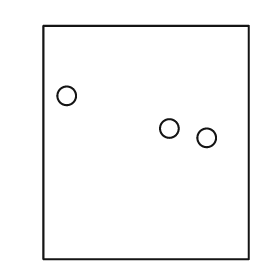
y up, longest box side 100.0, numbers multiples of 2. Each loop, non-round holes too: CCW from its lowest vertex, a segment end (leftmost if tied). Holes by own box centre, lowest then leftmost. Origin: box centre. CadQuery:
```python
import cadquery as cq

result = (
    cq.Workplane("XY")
    .moveTo(-44.0, -50.0)
    .lineTo(44.0, -50.0)
    .lineTo(44.0, 50.0)
    .lineTo(-44.0, 50.0)
    .close()
    .moveTo(26.0, 2.0)
    .circle(4.0)
    .moveTo(10.0, 6.0)
    .circle(4.0)
    .moveTo(-34.0, 20.0)
    .circle(4.0)
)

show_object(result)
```